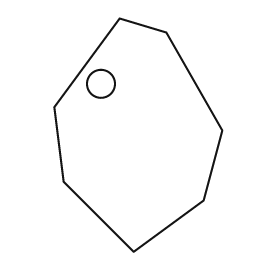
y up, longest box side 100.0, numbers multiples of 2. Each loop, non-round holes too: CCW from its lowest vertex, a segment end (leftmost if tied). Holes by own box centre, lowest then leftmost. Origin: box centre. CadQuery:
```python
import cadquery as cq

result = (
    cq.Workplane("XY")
    .moveTo(-2.0, -50.0)
    .lineTo(28.0, -28.0)
    .lineTo(36.0, 2.0)
    .lineTo(12.0, 44.0)
    .lineTo(-8.0, 50.0)
    .lineTo(-36.0, 12.0)
    .lineTo(-32.0, -20.0)
    .close()
    .moveTo(-16.0, 22.0)
    .circle(6.0)
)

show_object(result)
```